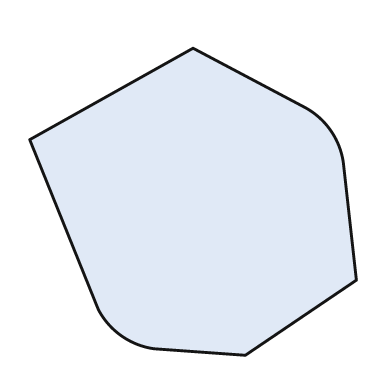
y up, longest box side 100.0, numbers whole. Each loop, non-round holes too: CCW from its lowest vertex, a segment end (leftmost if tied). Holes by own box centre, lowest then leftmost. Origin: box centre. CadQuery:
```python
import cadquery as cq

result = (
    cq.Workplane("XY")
    .moveTo(16.0, -47.0)
    .lineTo(50.0, -24.0)
    .lineTo(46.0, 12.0)
    .threePointArc((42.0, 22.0), (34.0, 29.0))
    .lineTo(0.0, 47.0)
    .lineTo(-50.0, 19.0)
    .lineTo(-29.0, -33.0)
    .threePointArc((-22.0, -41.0), (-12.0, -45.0))
    .close()
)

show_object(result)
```